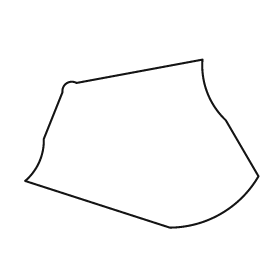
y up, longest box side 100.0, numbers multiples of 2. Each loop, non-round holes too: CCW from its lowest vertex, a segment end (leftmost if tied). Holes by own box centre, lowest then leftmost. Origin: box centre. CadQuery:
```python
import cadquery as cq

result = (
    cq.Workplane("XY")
    .moveTo(12.0, -36.0)
    .threePointArc((34.0, -30.0), (50.0, -14.0))
    .lineTo(36.0, 10.0)
    .threePointArc((28.0, 22.0), (26.0, 36.0))
    .lineTo(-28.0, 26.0)
    .threePointArc((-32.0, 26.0), (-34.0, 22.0))
    .lineTo(-42.0, 2.0)
    .threePointArc((-44.0, -8.0), (-50.0, -16.0))
    .close()
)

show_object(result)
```